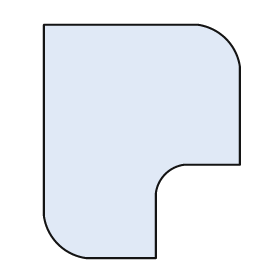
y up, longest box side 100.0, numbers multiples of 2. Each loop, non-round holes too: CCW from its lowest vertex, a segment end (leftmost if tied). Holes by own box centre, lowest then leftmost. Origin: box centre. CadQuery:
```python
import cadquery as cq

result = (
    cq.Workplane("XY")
    .moveTo(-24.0, -50.0)
    .lineTo(6.0, -50.0)
    .lineTo(6.0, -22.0)
    .threePointArc((10.0, -14.0), (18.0, -10.0))
    .lineTo(42.0, -10.0)
    .lineTo(42.0, 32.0)
    .threePointArc((36.0, 44.0), (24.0, 50.0))
    .lineTo(-42.0, 50.0)
    .lineTo(-42.0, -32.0)
    .threePointArc((-36.0, -44.0), (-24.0, -50.0))
    .close()
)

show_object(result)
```